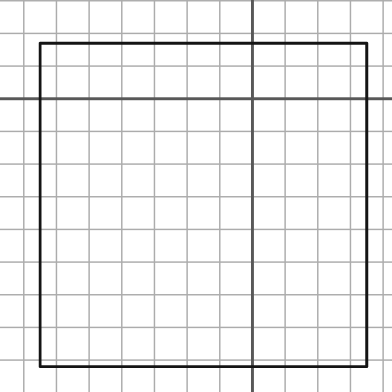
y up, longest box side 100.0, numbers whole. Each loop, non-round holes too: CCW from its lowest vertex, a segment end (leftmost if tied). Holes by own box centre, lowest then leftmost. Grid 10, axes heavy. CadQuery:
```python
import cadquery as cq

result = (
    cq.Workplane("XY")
    .moveTo(-65.0, -82.0)
    .lineTo(35.0, -82.0)
    .lineTo(35.0, 17.0)
    .lineTo(-65.0, 17.0)
    .close()
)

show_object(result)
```